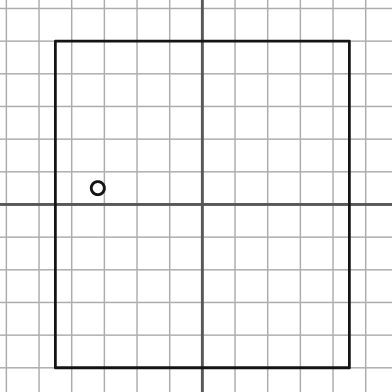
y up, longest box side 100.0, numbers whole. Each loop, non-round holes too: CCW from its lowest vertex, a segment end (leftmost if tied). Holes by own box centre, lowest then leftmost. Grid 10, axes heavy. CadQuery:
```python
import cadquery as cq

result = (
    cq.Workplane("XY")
    .moveTo(-45.0, -50.0)
    .lineTo(45.0, -50.0)
    .lineTo(45.0, 50.0)
    .lineTo(-45.0, 50.0)
    .close()
    .moveTo(-32.0, 5.0)
    .circle(2.0)
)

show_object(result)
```